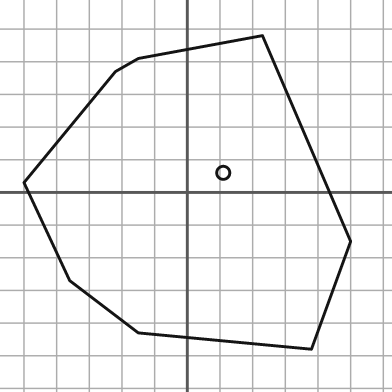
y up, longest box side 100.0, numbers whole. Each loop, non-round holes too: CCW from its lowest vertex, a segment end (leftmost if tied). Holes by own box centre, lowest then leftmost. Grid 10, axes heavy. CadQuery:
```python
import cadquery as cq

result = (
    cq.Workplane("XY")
    .moveTo(38.0, -48.0)
    .lineTo(50.0, -15.0)
    .lineTo(23.0, 48.0)
    .lineTo(-15.0, 41.0)
    .lineTo(-22.0, 37.0)
    .lineTo(-50.0, 3.0)
    .lineTo(-36.0, -27.0)
    .lineTo(-15.0, -43.0)
    .close()
    .moveTo(11.0, 6.0)
    .circle(2.0)
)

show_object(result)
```